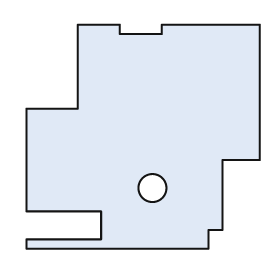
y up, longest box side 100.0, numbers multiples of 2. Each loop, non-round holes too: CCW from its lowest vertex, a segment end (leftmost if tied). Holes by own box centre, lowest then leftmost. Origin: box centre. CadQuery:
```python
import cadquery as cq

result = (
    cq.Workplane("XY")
    .moveTo(-50.0, -48.0)
    .lineTo(28.0, -48.0)
    .lineTo(28.0, -40.0)
    .lineTo(34.0, -40.0)
    .lineTo(34.0, -10.0)
    .lineTo(50.0, -10.0)
    .lineTo(50.0, 48.0)
    .lineTo(8.0, 48.0)
    .lineTo(8.0, 44.0)
    .lineTo(-10.0, 44.0)
    .lineTo(-10.0, 48.0)
    .lineTo(-28.0, 48.0)
    .lineTo(-28.0, 12.0)
    .lineTo(-50.0, 12.0)
    .lineTo(-50.0, -32.0)
    .lineTo(-18.0, -32.0)
    .lineTo(-18.0, -44.0)
    .lineTo(-50.0, -44.0)
    .close()
    .moveTo(4.0, -22.0)
    .circle(6.0)
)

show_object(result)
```